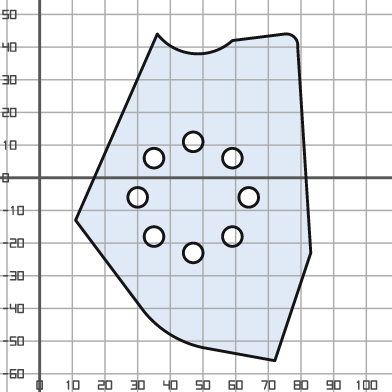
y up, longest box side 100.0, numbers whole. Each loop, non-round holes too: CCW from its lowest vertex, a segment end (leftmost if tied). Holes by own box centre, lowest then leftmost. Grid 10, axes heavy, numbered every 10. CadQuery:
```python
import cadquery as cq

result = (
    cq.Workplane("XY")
    .moveTo(72.0, -56.0)
    .lineTo(83.0, -23.0)
    .lineTo(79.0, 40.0)
    .threePointArc((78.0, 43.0), (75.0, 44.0))
    .lineTo(59.0, 42.0)
    .threePointArc((47.0, 38.0), (36.0, 44.0))
    .lineTo(11.0, -13.0)
    .lineTo(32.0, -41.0)
    .threePointArc((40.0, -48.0), (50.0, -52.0))
    .close()
    .moveTo(47.0, -23.0)
    .circle(3.0)
    .moveTo(35.0, -18.0)
    .circle(3.0)
    .moveTo(59.0, -18.0)
    .circle(3.0)
    .moveTo(30.0, -6.0)
    .circle(3.0)
    .moveTo(64.0, -6.0)
    .circle(3.0)
    .moveTo(35.0, 6.0)
    .circle(3.0)
    .moveTo(59.0, 6.0)
    .circle(3.0)
    .moveTo(47.0, 11.0)
    .circle(3.0)
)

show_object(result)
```